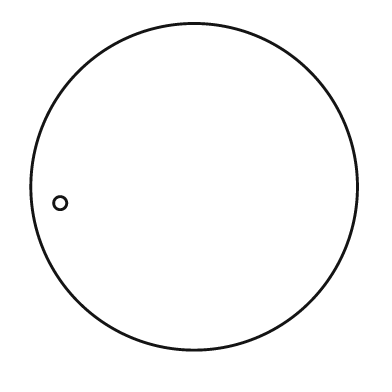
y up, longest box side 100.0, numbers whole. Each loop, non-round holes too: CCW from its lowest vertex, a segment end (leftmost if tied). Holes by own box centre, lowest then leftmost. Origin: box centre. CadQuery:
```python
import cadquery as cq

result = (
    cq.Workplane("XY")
    .moveTo(0.0, 0.0)
    .circle(50.0)
    .moveTo(-41.0, -5.0)
    .circle(2.0)
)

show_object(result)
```